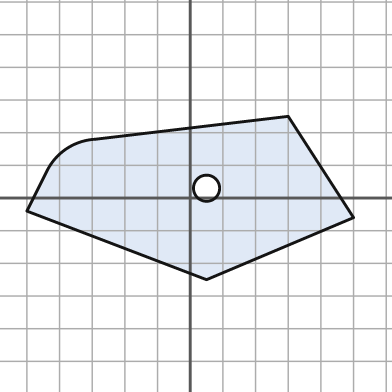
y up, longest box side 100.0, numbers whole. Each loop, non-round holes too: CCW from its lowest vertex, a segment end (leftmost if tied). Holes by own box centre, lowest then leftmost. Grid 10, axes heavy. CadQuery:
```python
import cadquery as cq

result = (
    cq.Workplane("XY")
    .moveTo(5.0, -25.0)
    .lineTo(50.0, -6.0)
    .lineTo(30.0, 25.0)
    .lineTo(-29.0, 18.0)
    .threePointArc((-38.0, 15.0), (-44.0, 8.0))
    .lineTo(-50.0, -4.0)
    .close()
    .moveTo(5.0, 3.0)
    .circle(4.0)
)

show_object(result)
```